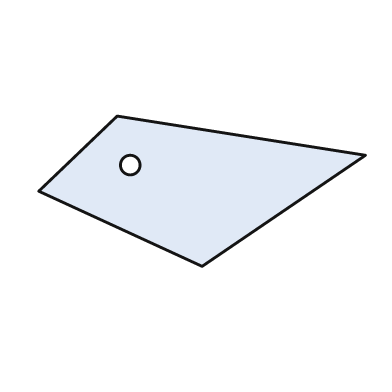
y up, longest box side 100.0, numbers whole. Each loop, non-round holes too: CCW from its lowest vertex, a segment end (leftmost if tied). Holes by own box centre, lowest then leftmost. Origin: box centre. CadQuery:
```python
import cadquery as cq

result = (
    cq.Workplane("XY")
    .moveTo(0.0, -23.0)
    .lineTo(50.0, 11.0)
    .lineTo(-26.0, 23.0)
    .lineTo(-50.0, 0.0)
    .close()
    .moveTo(-22.0, 8.0)
    .circle(3.0)
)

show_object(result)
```